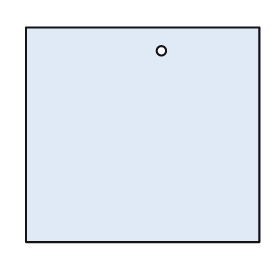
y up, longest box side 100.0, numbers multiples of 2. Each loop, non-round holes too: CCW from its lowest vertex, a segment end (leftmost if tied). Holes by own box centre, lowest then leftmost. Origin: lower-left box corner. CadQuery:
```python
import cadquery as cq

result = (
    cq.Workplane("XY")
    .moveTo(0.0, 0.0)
    .lineTo(100.0, 0.0)
    .lineTo(100.0, 92.0)
    .lineTo(0.0, 92.0)
    .close()
    .moveTo(58.0, 82.0)
    .circle(2.0)
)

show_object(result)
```